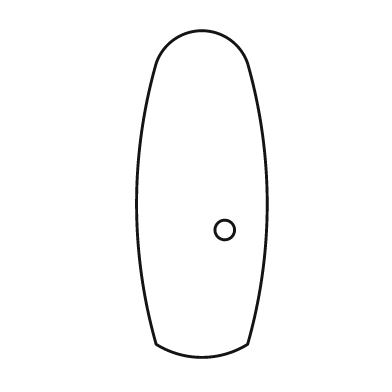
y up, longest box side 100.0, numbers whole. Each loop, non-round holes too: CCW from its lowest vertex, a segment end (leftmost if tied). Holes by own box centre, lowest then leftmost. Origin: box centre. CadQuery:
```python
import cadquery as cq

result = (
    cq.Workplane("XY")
    .moveTo(-14.0, -46.0)
    .threePointArc((0.0, -50.0), (14.0, -46.0))
    .threePointArc((20.0, -3.0), (14.0, 40.0))
    .threePointArc((0.0, 50.0), (-14.0, 40.0))
    .threePointArc((-20.0, -3.0), (-14.0, -46.0))
    .close()
    .moveTo(7.0, -11.0)
    .circle(3.0)
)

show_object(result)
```